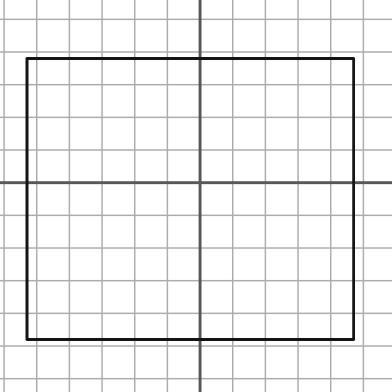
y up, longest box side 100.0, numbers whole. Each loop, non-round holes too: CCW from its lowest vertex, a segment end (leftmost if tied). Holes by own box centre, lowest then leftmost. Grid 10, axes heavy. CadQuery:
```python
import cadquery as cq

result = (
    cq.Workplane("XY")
    .moveTo(-53.0, -48.0)
    .lineTo(47.0, -48.0)
    .lineTo(47.0, 38.0)
    .lineTo(-53.0, 38.0)
    .close()
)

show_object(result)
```